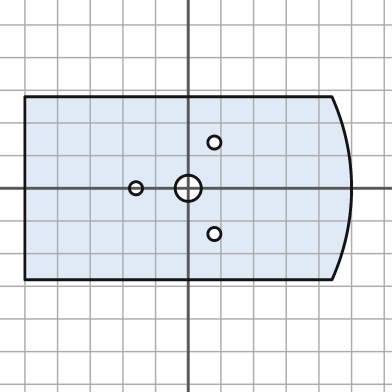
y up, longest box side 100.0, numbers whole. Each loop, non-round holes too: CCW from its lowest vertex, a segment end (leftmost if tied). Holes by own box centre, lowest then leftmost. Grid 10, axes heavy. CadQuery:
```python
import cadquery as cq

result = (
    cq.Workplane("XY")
    .moveTo(-50.0, -28.0)
    .lineTo(44.0, -28.0)
    .threePointArc((50.0, 0.0), (44.0, 28.0))
    .lineTo(-50.0, 28.0)
    .close()
    .moveTo(8.0, -14.0)
    .circle(2.0)
    .moveTo(-16.0, 0.0)
    .circle(2.0)
    .moveTo(0.0, 0.0)
    .circle(4.0)
    .moveTo(8.0, 14.0)
    .circle(2.0)
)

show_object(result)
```